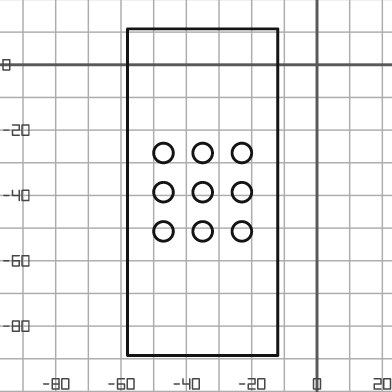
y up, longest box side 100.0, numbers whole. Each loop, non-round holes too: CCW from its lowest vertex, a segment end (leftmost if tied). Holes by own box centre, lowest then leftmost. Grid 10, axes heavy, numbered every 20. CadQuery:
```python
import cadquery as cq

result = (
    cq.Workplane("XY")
    .moveTo(-58.0, -89.0)
    .lineTo(-12.0, -89.0)
    .lineTo(-12.0, 11.0)
    .lineTo(-58.0, 11.0)
    .close()
    .moveTo(-47.0, -51.0)
    .circle(3.0)
    .moveTo(-35.0, -51.0)
    .circle(3.0)
    .moveTo(-23.0, -51.0)
    .circle(3.0)
    .moveTo(-47.0, -39.0)
    .circle(3.0)
    .moveTo(-35.0, -39.0)
    .circle(3.0)
    .moveTo(-23.0, -39.0)
    .circle(3.0)
    .moveTo(-47.0, -27.0)
    .circle(3.0)
    .moveTo(-35.0, -27.0)
    .circle(3.0)
    .moveTo(-23.0, -27.0)
    .circle(3.0)
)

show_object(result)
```